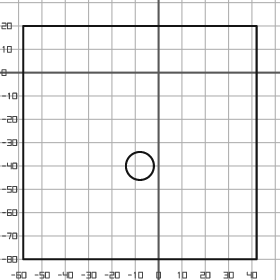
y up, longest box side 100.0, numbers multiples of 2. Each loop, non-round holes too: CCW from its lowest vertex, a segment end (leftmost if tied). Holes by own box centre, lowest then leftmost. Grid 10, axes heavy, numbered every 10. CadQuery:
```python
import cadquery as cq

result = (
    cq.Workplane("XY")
    .moveTo(-58.0, -80.0)
    .lineTo(42.0, -80.0)
    .lineTo(42.0, 20.0)
    .lineTo(-58.0, 20.0)
    .close()
    .moveTo(-8.0, -40.0)
    .circle(6.0)
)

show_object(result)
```